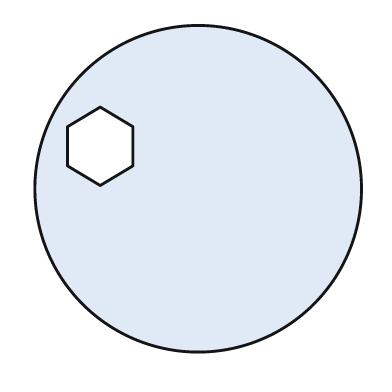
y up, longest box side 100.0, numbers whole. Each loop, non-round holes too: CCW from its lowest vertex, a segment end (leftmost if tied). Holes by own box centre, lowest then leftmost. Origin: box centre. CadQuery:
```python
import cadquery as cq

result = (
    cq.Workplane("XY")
    .moveTo(0.0, 0.0)
    .circle(50.0)
    .moveTo(-30.0, 1.0)
    .lineTo(-20.0, 7.0)
    .lineTo(-20.0, 19.0)
    .lineTo(-30.0, 25.0)
    .lineTo(-40.0, 19.0)
    .lineTo(-40.0, 7.0)
    .close()
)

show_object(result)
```